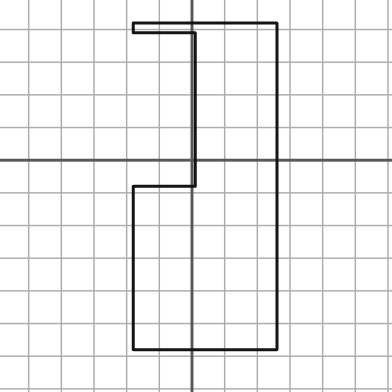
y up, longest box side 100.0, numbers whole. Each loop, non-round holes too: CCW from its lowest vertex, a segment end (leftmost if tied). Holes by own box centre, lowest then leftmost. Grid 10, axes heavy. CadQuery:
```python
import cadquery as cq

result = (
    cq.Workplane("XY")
    .moveTo(-18.0, -58.0)
    .lineTo(26.0, -58.0)
    .lineTo(26.0, 42.0)
    .lineTo(-18.0, 42.0)
    .lineTo(-18.0, 39.0)
    .lineTo(1.0, 39.0)
    .lineTo(1.0, -8.0)
    .lineTo(-18.0, -8.0)
    .close()
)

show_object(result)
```